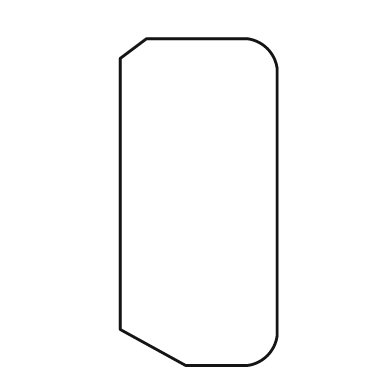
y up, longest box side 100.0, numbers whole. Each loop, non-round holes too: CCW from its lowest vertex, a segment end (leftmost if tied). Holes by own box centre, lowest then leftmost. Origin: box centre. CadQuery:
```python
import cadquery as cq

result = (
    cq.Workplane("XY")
    .moveTo(-4.0, -50.0)
    .lineTo(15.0, -50.0)
    .threePointArc((21.0, -47.0), (24.0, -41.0))
    .lineTo(24.0, 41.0)
    .threePointArc((21.0, 47.0), (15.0, 50.0))
    .lineTo(-16.0, 50.0)
    .lineTo(-24.0, 44.0)
    .lineTo(-24.0, -39.0)
    .close()
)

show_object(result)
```